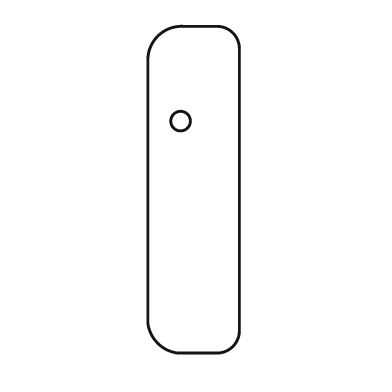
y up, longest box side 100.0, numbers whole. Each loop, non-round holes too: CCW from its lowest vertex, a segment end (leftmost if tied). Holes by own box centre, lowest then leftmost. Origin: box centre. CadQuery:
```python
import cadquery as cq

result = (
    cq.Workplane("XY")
    .moveTo(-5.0, -50.0)
    .lineTo(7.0, -50.0)
    .threePointArc((12.0, -48.0), (14.0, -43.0))
    .lineTo(14.0, 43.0)
    .threePointArc((12.0, 48.0), (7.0, 50.0))
    .lineTo(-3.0, 50.0)
    .threePointArc((-11.0, 47.0), (-14.0, 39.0))
    .lineTo(-14.0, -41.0)
    .threePointArc((-11.0, -47.0), (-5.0, -50.0))
    .close()
    .moveTo(-4.0, 21.0)
    .circle(3.0)
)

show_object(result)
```